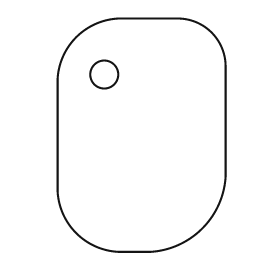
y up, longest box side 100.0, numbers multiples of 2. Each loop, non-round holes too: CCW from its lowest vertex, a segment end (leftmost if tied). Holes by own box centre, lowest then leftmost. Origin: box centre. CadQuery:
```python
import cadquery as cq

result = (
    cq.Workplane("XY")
    .moveTo(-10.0, -50.0)
    .lineTo(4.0, -50.0)
    .threePointArc((26.0, -40.0), (36.0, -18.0))
    .lineTo(36.0, 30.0)
    .threePointArc((30.0, 44.0), (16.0, 50.0))
    .lineTo(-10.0, 50.0)
    .threePointArc((-28.0, 42.0), (-36.0, 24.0))
    .lineTo(-36.0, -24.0)
    .threePointArc((-28.0, -42.0), (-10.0, -50.0))
    .close()
    .moveTo(-16.0, 26.0)
    .circle(6.0)
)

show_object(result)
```